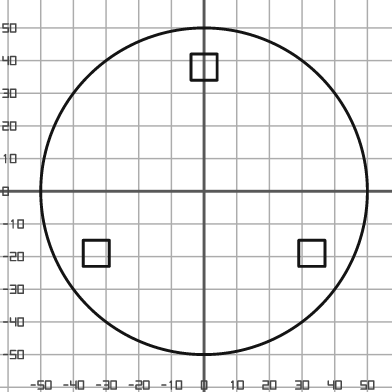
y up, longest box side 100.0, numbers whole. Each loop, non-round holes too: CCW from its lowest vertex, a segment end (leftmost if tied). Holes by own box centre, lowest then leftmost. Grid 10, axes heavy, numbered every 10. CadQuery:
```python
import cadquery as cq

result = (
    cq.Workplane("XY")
    .moveTo(0.0, 0.0)
    .circle(50.0)
    .moveTo(-37.0, -23.0)
    .lineTo(-29.0, -23.0)
    .lineTo(-29.0, -15.0)
    .lineTo(-37.0, -15.0)
    .close()
    .moveTo(29.0, -23.0)
    .lineTo(37.0, -23.0)
    .lineTo(37.0, -15.0)
    .lineTo(29.0, -15.0)
    .close()
    .moveTo(-4.0, 34.0)
    .lineTo(4.0, 34.0)
    .lineTo(4.0, 42.0)
    .lineTo(-4.0, 42.0)
    .close()
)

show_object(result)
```